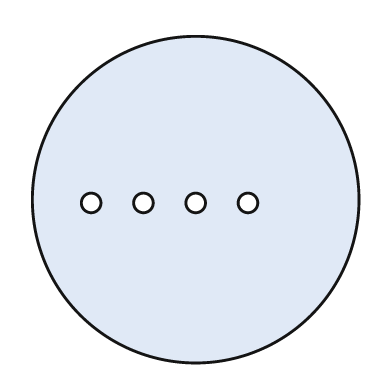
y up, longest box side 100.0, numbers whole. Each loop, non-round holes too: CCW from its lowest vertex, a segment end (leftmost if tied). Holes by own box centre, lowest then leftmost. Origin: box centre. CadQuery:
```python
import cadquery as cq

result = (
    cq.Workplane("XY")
    .moveTo(0.0, 0.0)
    .circle(50.0)
    .moveTo(-32.0, -1.0)
    .circle(3.0)
    .moveTo(-16.0, -1.0)
    .circle(3.0)
    .moveTo(0.0, -1.0)
    .circle(3.0)
    .moveTo(16.0, -1.0)
    .circle(3.0)
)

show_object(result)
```